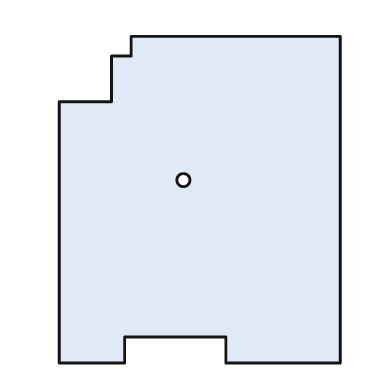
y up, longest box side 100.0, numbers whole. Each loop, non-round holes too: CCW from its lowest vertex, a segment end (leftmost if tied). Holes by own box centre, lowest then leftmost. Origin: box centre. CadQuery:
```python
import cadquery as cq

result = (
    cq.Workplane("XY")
    .moveTo(-43.0, -50.0)
    .lineTo(-23.0, -50.0)
    .lineTo(-23.0, -42.0)
    .lineTo(8.0, -42.0)
    .lineTo(8.0, -50.0)
    .lineTo(43.0, -50.0)
    .lineTo(43.0, 50.0)
    .lineTo(-21.0, 50.0)
    .lineTo(-21.0, 44.0)
    .lineTo(-27.0, 44.0)
    .lineTo(-27.0, 30.0)
    .lineTo(-43.0, 30.0)
    .close()
    .moveTo(-5.0, 6.0)
    .circle(2.0)
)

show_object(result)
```